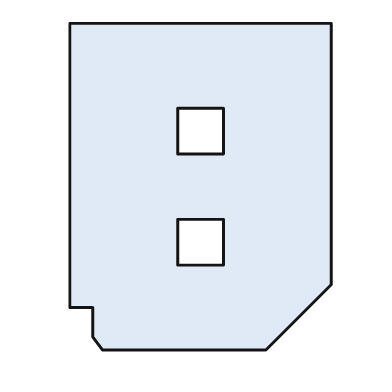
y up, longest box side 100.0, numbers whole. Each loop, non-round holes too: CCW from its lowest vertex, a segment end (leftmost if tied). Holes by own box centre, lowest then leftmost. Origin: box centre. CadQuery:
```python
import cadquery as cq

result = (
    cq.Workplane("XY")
    .moveTo(-30.0, -50.0)
    .lineTo(20.0, -50.0)
    .lineTo(40.0, -30.0)
    .lineTo(40.0, 50.0)
    .lineTo(-40.0, 50.0)
    .lineTo(-40.0, -37.0)
    .lineTo(-33.0, -37.0)
    .lineTo(-33.0, -46.0)
    .close()
    .moveTo(-7.0, -24.0)
    .lineTo(7.0, -24.0)
    .lineTo(7.0, -10.0)
    .lineTo(-7.0, -10.0)
    .close()
    .moveTo(-7.0, 10.0)
    .lineTo(7.0, 10.0)
    .lineTo(7.0, 24.0)
    .lineTo(-7.0, 24.0)
    .close()
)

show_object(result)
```